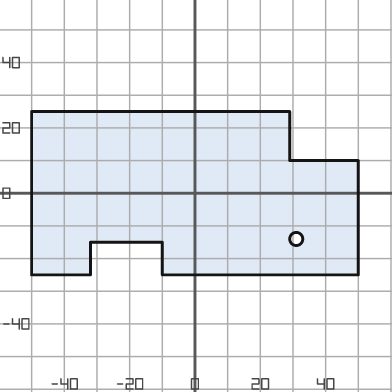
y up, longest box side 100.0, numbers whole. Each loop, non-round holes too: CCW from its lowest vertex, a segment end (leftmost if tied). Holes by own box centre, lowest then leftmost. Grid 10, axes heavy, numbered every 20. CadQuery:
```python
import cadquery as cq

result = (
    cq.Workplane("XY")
    .moveTo(-50.0, -25.0)
    .lineTo(-32.0, -25.0)
    .lineTo(-32.0, -15.0)
    .lineTo(-10.0, -15.0)
    .lineTo(-10.0, -25.0)
    .lineTo(50.0, -25.0)
    .lineTo(50.0, 10.0)
    .lineTo(29.0, 10.0)
    .lineTo(29.0, 25.0)
    .lineTo(-50.0, 25.0)
    .close()
    .moveTo(31.0, -14.0)
    .circle(2.0)
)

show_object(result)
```